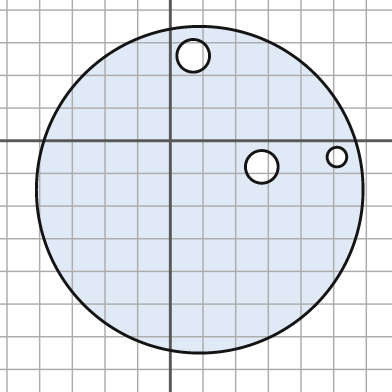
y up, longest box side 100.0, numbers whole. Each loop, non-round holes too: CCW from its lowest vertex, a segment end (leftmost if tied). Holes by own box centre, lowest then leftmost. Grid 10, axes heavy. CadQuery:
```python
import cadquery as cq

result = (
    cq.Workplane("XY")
    .moveTo(9.0, -15.0)
    .circle(50.0)
    .moveTo(28.0, -8.0)
    .circle(5.0)
    .moveTo(51.0, -5.0)
    .circle(3.0)
    .moveTo(7.0, 26.0)
    .circle(5.0)
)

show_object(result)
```